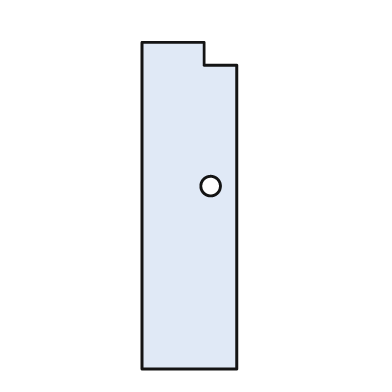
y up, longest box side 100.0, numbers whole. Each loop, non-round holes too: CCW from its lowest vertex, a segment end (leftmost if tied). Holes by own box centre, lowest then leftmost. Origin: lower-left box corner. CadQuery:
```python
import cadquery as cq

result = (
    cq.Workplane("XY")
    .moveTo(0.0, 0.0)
    .lineTo(29.0, 0.0)
    .lineTo(29.0, 93.0)
    .lineTo(19.0, 93.0)
    .lineTo(19.0, 100.0)
    .lineTo(0.0, 100.0)
    .close()
    .moveTo(21.0, 56.0)
    .circle(3.0)
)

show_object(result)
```